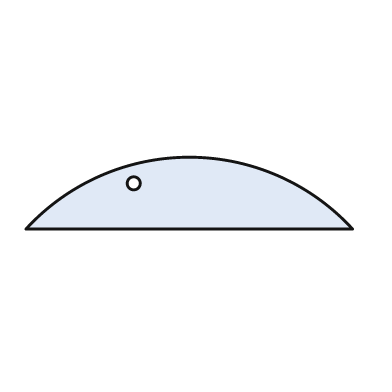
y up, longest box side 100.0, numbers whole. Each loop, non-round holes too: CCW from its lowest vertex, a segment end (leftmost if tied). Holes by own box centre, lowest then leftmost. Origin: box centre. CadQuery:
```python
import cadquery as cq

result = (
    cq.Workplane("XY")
    .moveTo(-50.0, -11.0)
    .lineTo(50.0, -11.0)
    .threePointArc((0.0, 11.0), (-50.0, -11.0))
    .close()
    .moveTo(-17.0, 3.0)
    .circle(2.0)
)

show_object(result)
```